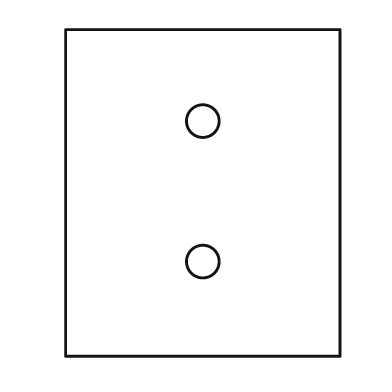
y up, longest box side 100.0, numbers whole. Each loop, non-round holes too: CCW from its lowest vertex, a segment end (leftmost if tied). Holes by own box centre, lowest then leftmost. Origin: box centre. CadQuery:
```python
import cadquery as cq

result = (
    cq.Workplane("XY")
    .moveTo(-42.0, -50.0)
    .lineTo(42.0, -50.0)
    .lineTo(42.0, 50.0)
    .lineTo(-42.0, 50.0)
    .close()
    .moveTo(0.0, -21.0)
    .circle(5.0)
    .moveTo(0.0, 22.0)
    .circle(5.0)
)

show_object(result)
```